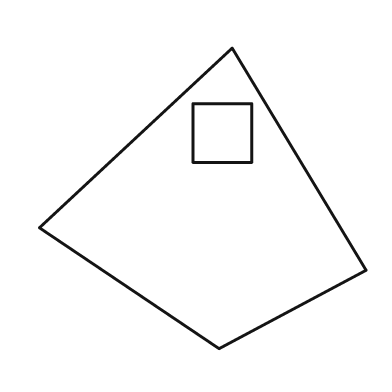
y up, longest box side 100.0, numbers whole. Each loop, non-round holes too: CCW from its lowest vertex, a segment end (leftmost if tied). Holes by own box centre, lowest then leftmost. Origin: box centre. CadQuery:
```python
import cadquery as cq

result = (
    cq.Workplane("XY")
    .moveTo(5.0, -46.0)
    .lineTo(50.0, -22.0)
    .lineTo(9.0, 46.0)
    .lineTo(-50.0, -9.0)
    .close()
    .moveTo(-3.0, 11.0)
    .lineTo(15.0, 11.0)
    .lineTo(15.0, 29.0)
    .lineTo(-3.0, 29.0)
    .close()
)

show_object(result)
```